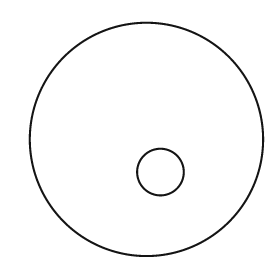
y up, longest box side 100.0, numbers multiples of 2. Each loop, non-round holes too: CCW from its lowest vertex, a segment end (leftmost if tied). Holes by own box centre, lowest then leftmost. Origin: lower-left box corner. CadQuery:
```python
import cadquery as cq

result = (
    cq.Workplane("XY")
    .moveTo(50.0, 50.0)
    .circle(50.0)
    .moveTo(56.0, 36.0)
    .circle(10.0)
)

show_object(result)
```